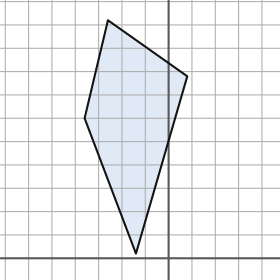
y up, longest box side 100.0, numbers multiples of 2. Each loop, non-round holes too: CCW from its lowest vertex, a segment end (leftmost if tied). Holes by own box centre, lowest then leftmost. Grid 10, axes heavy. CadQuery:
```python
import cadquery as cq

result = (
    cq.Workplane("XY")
    .moveTo(-14.0, 2.0)
    .lineTo(8.0, 78.0)
    .lineTo(-26.0, 102.0)
    .lineTo(-36.0, 60.0)
    .close()
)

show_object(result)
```